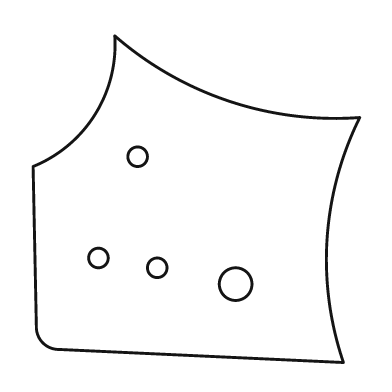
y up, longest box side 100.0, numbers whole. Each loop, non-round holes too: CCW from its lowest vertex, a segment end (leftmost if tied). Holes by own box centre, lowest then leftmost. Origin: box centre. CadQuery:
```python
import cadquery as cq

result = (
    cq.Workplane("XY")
    .moveTo(45.0, -50.0)
    .threePointArc((40.0, -12.0), (50.0, 25.0))
    .threePointArc((10.0, 30.0), (-25.0, 50.0))
    .threePointArc((-31.0, 26.0), (-50.0, 10.0))
    .lineTo(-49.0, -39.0)
    .threePointArc((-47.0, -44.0), (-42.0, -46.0))
    .close()
    .moveTo(12.0, -26.0)
    .circle(5.0)
    .moveTo(-12.0, -21.0)
    .circle(3.0)
    .moveTo(-30.0, -18.0)
    .circle(3.0)
    .moveTo(-18.0, 13.0)
    .circle(3.0)
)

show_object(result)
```